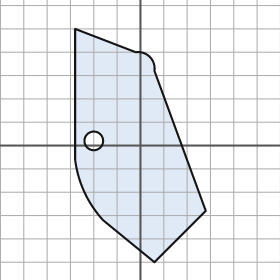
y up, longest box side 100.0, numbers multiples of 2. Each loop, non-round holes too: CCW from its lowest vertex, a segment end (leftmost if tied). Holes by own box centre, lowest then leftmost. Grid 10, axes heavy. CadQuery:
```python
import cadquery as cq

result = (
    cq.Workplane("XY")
    .moveTo(6.0, -50.0)
    .lineTo(28.0, -28.0)
    .lineTo(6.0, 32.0)
    .threePointArc((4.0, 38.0), (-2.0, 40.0))
    .lineTo(-28.0, 50.0)
    .lineTo(-28.0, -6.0)
    .threePointArc((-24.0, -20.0), (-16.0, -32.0))
    .close()
    .moveTo(-20.0, 2.0)
    .circle(4.0)
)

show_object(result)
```